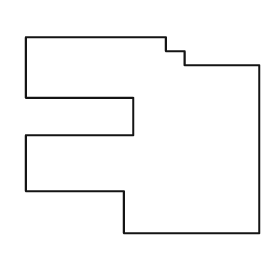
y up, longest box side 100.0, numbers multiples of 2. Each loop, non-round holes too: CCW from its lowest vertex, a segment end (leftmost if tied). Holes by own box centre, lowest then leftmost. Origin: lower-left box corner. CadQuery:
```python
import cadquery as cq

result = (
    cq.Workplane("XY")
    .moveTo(42.0, 0.0)
    .lineTo(100.0, 0.0)
    .lineTo(100.0, 72.0)
    .lineTo(68.0, 72.0)
    .lineTo(68.0, 78.0)
    .lineTo(60.0, 78.0)
    .lineTo(60.0, 84.0)
    .lineTo(0.0, 84.0)
    .lineTo(0.0, 58.0)
    .lineTo(46.0, 58.0)
    .lineTo(46.0, 42.0)
    .lineTo(0.0, 42.0)
    .lineTo(0.0, 18.0)
    .lineTo(42.0, 18.0)
    .close()
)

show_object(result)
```